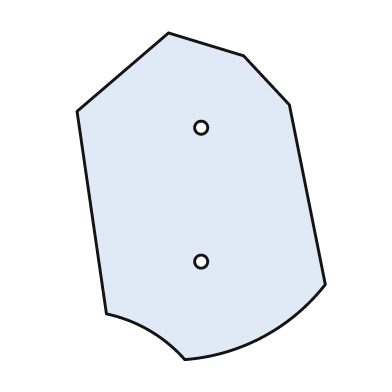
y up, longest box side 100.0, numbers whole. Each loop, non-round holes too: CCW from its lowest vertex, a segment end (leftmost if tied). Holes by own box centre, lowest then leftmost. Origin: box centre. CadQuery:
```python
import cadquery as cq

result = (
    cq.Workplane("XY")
    .moveTo(-5.0, -50.0)
    .threePointArc((19.0, -43.0), (38.0, -27.0))
    .lineTo(27.0, 28.0)
    .lineTo(13.0, 43.0)
    .lineTo(-10.0, 50.0)
    .lineTo(-38.0, 26.0)
    .lineTo(-29.0, -36.0)
    .threePointArc((-16.0, -41.0), (-5.0, -50.0))
    .close()
    .moveTo(0.0, -20.0)
    .circle(2.0)
    .moveTo(0.0, 21.0)
    .circle(2.0)
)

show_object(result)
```